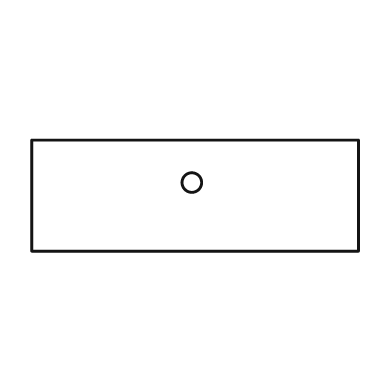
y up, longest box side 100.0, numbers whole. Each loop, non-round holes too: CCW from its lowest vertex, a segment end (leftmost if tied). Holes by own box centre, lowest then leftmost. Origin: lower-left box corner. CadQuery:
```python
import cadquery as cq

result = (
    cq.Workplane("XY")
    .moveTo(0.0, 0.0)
    .lineTo(100.0, 0.0)
    .lineTo(100.0, 34.0)
    .lineTo(0.0, 34.0)
    .close()
    .moveTo(49.0, 21.0)
    .circle(3.0)
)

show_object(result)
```